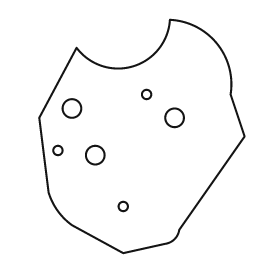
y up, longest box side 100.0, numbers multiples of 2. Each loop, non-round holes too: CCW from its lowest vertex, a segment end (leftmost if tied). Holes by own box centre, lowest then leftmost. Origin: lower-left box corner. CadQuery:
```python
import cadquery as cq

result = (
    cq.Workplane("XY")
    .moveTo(36.0, 0.0)
    .lineTo(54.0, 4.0)
    .threePointArc((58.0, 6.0), (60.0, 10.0))
    .lineTo(88.0, 50.0)
    .lineTo(82.0, 68.0)
    .threePointArc((76.0, 90.0), (56.0, 100.0))
    .threePointArc((40.0, 80.0), (16.0, 88.0))
    .lineTo(0.0, 58.0)
    .lineTo(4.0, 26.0)
    .threePointArc((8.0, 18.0), (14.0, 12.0))
    .close()
    .moveTo(36.0, 20.0)
    .circle(2.0)
    .moveTo(24.0, 42.0)
    .circle(4.0)
    .moveTo(8.0, 44.0)
    .circle(2.0)
    .moveTo(58.0, 58.0)
    .circle(4.0)
    .moveTo(14.0, 62.0)
    .circle(4.0)
    .moveTo(46.0, 68.0)
    .circle(2.0)
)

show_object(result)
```